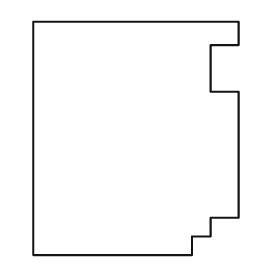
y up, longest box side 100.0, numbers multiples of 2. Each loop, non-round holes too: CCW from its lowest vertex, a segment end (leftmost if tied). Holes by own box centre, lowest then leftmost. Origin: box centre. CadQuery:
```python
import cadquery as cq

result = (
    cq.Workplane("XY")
    .moveTo(-44.0, -50.0)
    .lineTo(24.0, -50.0)
    .lineTo(24.0, -42.0)
    .lineTo(32.0, -42.0)
    .lineTo(32.0, -34.0)
    .lineTo(44.0, -34.0)
    .lineTo(44.0, 20.0)
    .lineTo(32.0, 20.0)
    .lineTo(32.0, 40.0)
    .lineTo(44.0, 40.0)
    .lineTo(44.0, 50.0)
    .lineTo(-44.0, 50.0)
    .close()
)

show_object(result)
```